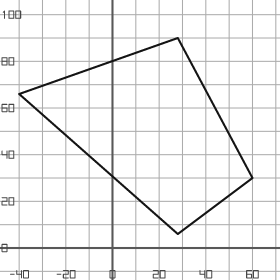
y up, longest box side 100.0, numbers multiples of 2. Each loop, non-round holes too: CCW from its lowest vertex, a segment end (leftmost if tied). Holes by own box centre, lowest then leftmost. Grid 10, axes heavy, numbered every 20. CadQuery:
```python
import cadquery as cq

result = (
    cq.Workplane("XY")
    .moveTo(28.0, 6.0)
    .lineTo(60.0, 30.0)
    .lineTo(28.0, 90.0)
    .lineTo(-40.0, 66.0)
    .close()
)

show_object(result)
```